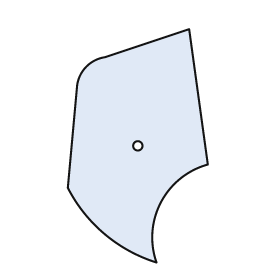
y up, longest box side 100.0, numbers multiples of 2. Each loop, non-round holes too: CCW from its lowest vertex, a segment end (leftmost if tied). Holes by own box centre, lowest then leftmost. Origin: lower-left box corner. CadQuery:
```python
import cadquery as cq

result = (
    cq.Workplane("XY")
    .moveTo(38.0, 0.0)
    .threePointArc((40.0, 26.0), (60.0, 42.0))
    .lineTo(52.0, 100.0)
    .lineTo(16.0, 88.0)
    .threePointArc((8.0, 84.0), (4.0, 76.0))
    .lineTo(0.0, 32.0)
    .threePointArc((16.0, 12.0), (38.0, 0.0))
    .close()
    .moveTo(30.0, 50.0)
    .circle(2.0)
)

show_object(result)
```